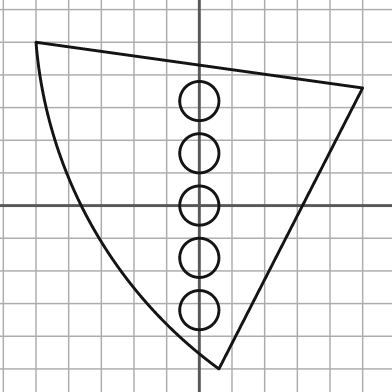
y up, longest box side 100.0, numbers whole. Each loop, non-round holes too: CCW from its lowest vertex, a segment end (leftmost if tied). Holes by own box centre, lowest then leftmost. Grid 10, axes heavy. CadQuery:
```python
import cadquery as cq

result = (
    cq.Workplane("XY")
    .moveTo(6.0, -50.0)
    .lineTo(50.0, 36.0)
    .lineTo(-50.0, 50.0)
    .threePointArc((-33.0, -6.0), (6.0, -50.0))
    .close()
    .moveTo(0.0, -32.0)
    .circle(6.0)
    .moveTo(0.0, -16.0)
    .circle(6.0)
    .moveTo(0.0, 0.0)
    .circle(6.0)
    .moveTo(0.0, 16.0)
    .circle(6.0)
    .moveTo(0.0, 32.0)
    .circle(6.0)
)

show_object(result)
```